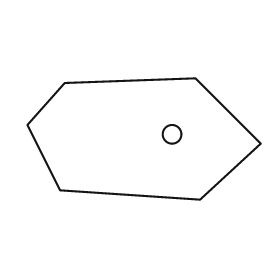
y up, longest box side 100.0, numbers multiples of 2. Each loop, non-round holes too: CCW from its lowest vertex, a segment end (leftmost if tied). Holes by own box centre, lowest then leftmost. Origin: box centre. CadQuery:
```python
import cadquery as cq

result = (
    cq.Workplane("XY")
    .moveTo(24.0, -26.0)
    .lineTo(50.0, -2.0)
    .lineTo(22.0, 26.0)
    .lineTo(-34.0, 24.0)
    .lineTo(-50.0, 6.0)
    .lineTo(-36.0, -22.0)
    .close()
    .moveTo(12.0, 2.0)
    .circle(4.0)
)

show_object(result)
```